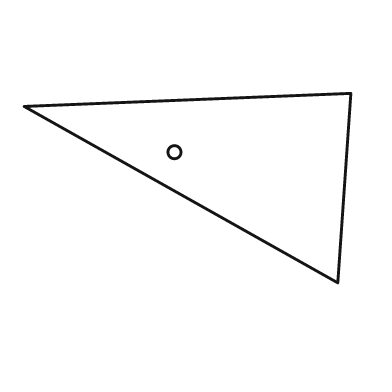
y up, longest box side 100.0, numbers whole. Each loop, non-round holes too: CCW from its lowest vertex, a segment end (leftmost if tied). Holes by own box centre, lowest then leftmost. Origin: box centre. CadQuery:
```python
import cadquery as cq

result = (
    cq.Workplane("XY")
    .moveTo(46.0, -29.0)
    .lineTo(50.0, 29.0)
    .lineTo(-50.0, 25.0)
    .close()
    .moveTo(-4.0, 11.0)
    .circle(2.0)
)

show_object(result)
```